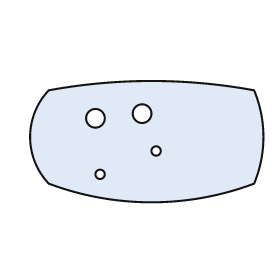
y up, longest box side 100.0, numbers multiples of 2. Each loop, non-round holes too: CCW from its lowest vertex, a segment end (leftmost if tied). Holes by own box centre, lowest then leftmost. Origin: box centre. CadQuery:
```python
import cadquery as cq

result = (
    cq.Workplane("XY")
    .moveTo(-42.0, -18.0)
    .threePointArc((2.0, -26.0), (46.0, -18.0))
    .threePointArc((50.0, 2.0), (46.0, 22.0))
    .threePointArc((2.0, 26.0), (-42.0, 22.0))
    .threePointArc((-50.0, 2.0), (-42.0, -18.0))
    .close()
    .moveTo(-20.0, -14.0)
    .circle(2.0)
    .moveTo(4.0, -4.0)
    .circle(2.0)
    .moveTo(-22.0, 10.0)
    .circle(4.0)
    .moveTo(-2.0, 12.0)
    .circle(4.0)
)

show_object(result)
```